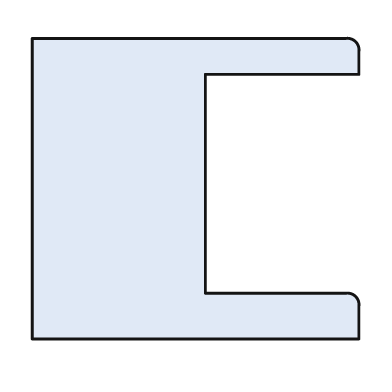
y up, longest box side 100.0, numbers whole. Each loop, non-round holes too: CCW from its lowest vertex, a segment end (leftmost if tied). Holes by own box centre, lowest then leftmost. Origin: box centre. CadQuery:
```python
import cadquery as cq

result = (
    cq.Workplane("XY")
    .moveTo(-50.0, -46.0)
    .lineTo(50.0, -46.0)
    .lineTo(50.0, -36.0)
    .threePointArc((49.0, -33.0), (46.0, -32.0))
    .lineTo(3.0, -32.0)
    .lineTo(3.0, 35.0)
    .lineTo(50.0, 35.0)
    .lineTo(50.0, 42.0)
    .threePointArc((49.0, 45.0), (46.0, 46.0))
    .lineTo(-50.0, 46.0)
    .close()
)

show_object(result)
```